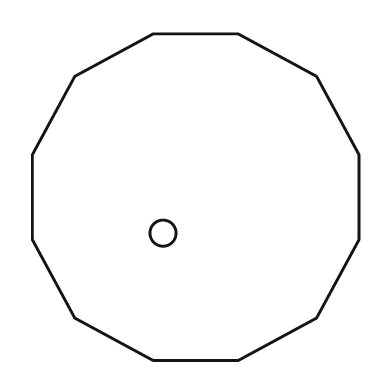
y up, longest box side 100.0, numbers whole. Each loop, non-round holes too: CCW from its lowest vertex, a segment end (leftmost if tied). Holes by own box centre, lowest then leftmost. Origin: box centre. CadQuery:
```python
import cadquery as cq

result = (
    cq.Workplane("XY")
    .moveTo(-13.0, -50.0)
    .lineTo(13.0, -50.0)
    .lineTo(37.0, -37.0)
    .lineTo(50.0, -13.0)
    .lineTo(50.0, 13.0)
    .lineTo(37.0, 37.0)
    .lineTo(13.0, 50.0)
    .lineTo(-13.0, 50.0)
    .lineTo(-37.0, 37.0)
    .lineTo(-50.0, 13.0)
    .lineTo(-50.0, -13.0)
    .lineTo(-37.0, -37.0)
    .close()
    .moveTo(-10.0, -11.0)
    .circle(4.0)
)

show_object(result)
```